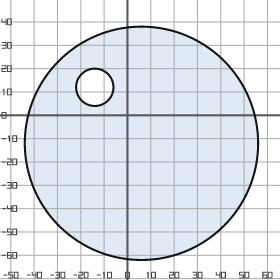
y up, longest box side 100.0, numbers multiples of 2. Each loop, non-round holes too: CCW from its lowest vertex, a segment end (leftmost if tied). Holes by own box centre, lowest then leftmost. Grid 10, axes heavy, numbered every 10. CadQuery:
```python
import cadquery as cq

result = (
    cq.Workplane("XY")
    .moveTo(6.0, -12.0)
    .circle(50.0)
    .moveTo(-14.0, 12.0)
    .circle(8.0)
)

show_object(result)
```